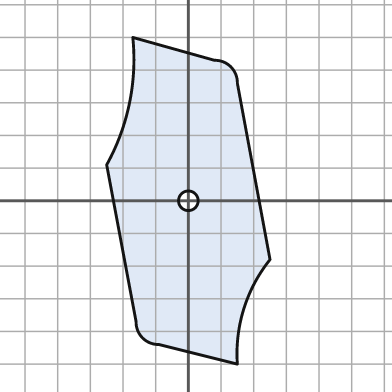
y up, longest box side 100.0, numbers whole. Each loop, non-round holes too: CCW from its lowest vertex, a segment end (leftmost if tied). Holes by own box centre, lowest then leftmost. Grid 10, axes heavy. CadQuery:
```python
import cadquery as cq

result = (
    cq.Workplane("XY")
    .moveTo(15.0, -50.0)
    .threePointArc((17.0, -33.0), (25.0, -18.0))
    .lineTo(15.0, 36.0)
    .threePointArc((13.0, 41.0), (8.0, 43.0))
    .lineTo(-17.0, 50.0)
    .threePointArc((-18.0, 30.0), (-25.0, 11.0))
    .lineTo(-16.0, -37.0)
    .threePointArc((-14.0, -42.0), (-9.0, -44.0))
    .close()
    .moveTo(0.0, 0.0)
    .circle(3.0)
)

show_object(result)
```